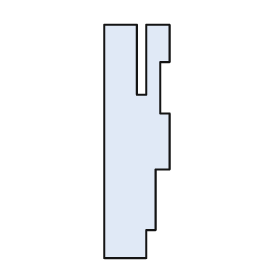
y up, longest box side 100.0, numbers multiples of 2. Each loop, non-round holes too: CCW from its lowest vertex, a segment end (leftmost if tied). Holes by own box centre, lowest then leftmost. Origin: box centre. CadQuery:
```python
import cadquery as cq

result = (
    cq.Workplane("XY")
    .moveTo(-14.0, -50.0)
    .lineTo(4.0, -50.0)
    .lineTo(4.0, -38.0)
    .lineTo(8.0, -38.0)
    .lineTo(8.0, -12.0)
    .lineTo(14.0, -12.0)
    .lineTo(14.0, 12.0)
    .lineTo(10.0, 12.0)
    .lineTo(10.0, 34.0)
    .lineTo(14.0, 34.0)
    .lineTo(14.0, 50.0)
    .lineTo(4.0, 50.0)
    .lineTo(4.0, 20.0)
    .lineTo(0.0, 20.0)
    .lineTo(0.0, 50.0)
    .lineTo(-14.0, 50.0)
    .close()
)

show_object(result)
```